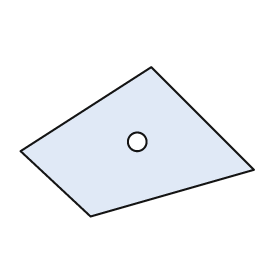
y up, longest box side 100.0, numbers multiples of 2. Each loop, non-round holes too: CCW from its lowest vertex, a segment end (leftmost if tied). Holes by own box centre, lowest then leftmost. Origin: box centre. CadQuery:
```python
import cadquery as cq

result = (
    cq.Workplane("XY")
    .moveTo(-20.0, -32.0)
    .lineTo(50.0, -12.0)
    .lineTo(6.0, 32.0)
    .lineTo(-50.0, -4.0)
    .close()
    .moveTo(0.0, 0.0)
    .circle(4.0)
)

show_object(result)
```